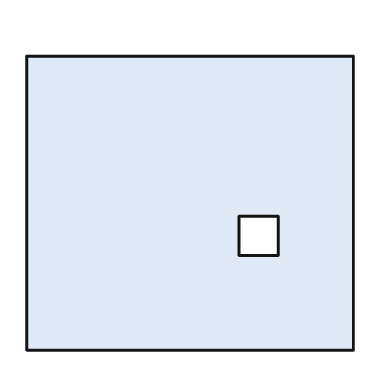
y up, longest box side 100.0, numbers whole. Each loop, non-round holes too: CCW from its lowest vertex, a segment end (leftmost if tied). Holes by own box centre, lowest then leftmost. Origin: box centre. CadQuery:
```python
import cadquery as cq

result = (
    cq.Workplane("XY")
    .moveTo(-50.0, -45.0)
    .lineTo(50.0, -45.0)
    .lineTo(50.0, 45.0)
    .lineTo(-50.0, 45.0)
    .close()
    .moveTo(15.0, -16.0)
    .lineTo(27.0, -16.0)
    .lineTo(27.0, -4.0)
    .lineTo(15.0, -4.0)
    .close()
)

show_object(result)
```